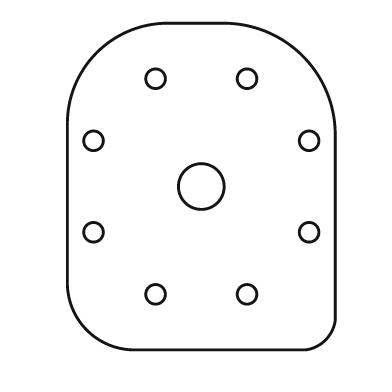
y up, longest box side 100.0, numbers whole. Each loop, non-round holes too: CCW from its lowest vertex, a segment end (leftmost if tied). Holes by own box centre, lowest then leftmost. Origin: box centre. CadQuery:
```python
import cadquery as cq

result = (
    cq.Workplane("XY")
    .moveTo(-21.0, -50.0)
    .lineTo(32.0, -50.0)
    .threePointArc((38.0, -47.0), (41.0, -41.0))
    .lineTo(41.0, 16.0)
    .threePointArc((31.0, 40.0), (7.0, 50.0))
    .lineTo(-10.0, 50.0)
    .threePointArc((-32.0, 41.0), (-41.0, 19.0))
    .lineTo(-41.0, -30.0)
    .threePointArc((-35.0, -44.0), (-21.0, -50.0))
    .close()
    .moveTo(-14.0, -33.0)
    .circle(3.0)
    .moveTo(14.0, -33.0)
    .circle(3.0)
    .moveTo(-33.0, -14.0)
    .circle(3.0)
    .moveTo(33.0, -14.0)
    .circle(3.0)
    .moveTo(0.0, 0.0)
    .circle(7.0)
    .moveTo(-33.0, 14.0)
    .circle(3.0)
    .moveTo(33.0, 14.0)
    .circle(3.0)
    .moveTo(-14.0, 33.0)
    .circle(3.0)
    .moveTo(14.0, 33.0)
    .circle(3.0)
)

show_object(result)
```